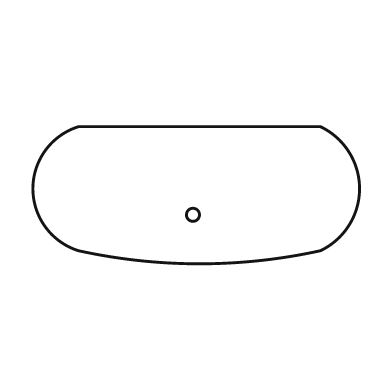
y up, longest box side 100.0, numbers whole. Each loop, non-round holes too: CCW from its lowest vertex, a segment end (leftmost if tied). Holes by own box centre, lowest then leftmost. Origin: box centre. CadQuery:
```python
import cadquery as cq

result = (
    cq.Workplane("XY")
    .moveTo(-36.0, -17.0)
    .threePointArc((1.0, -21.0), (38.0, -17.0))
    .threePointArc((50.0, 2.0), (38.0, 21.0))
    .lineTo(-36.0, 21.0)
    .threePointArc((-50.0, 2.0), (-36.0, -17.0))
    .close()
    .moveTo(-1.0, -6.0)
    .circle(2.0)
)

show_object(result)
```